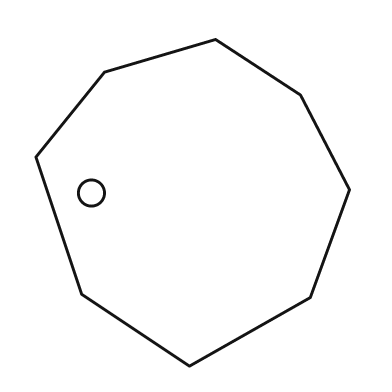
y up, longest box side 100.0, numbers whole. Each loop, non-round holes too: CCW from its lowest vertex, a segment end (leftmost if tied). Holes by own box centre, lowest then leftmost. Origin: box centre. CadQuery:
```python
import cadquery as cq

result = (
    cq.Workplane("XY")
    .moveTo(-1.0, -50.0)
    .lineTo(36.0, -29.0)
    .lineTo(48.0, 4.0)
    .lineTo(33.0, 33.0)
    .lineTo(7.0, 50.0)
    .lineTo(-27.0, 40.0)
    .lineTo(-48.0, 14.0)
    .lineTo(-34.0, -28.0)
    .close()
    .moveTo(-31.0, 3.0)
    .circle(4.0)
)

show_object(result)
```